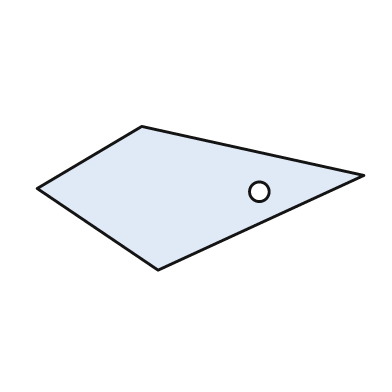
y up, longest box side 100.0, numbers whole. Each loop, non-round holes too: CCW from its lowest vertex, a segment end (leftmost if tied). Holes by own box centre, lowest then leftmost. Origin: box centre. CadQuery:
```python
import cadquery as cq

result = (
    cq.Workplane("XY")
    .moveTo(-13.0, -22.0)
    .lineTo(50.0, 7.0)
    .lineTo(-18.0, 22.0)
    .lineTo(-50.0, 3.0)
    .close()
    .moveTo(18.0, 2.0)
    .circle(3.0)
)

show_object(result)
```